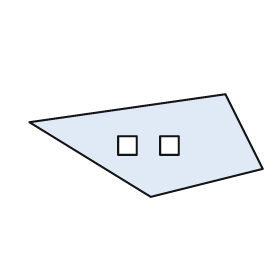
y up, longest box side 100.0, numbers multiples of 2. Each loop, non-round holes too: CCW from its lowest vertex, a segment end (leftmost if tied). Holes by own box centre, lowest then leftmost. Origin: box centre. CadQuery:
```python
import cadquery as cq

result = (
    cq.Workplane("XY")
    .moveTo(2.0, -22.0)
    .lineTo(50.0, -10.0)
    .lineTo(34.0, 22.0)
    .lineTo(-50.0, 10.0)
    .close()
    .moveTo(-12.0, -4.0)
    .lineTo(-4.0, -4.0)
    .lineTo(-4.0, 4.0)
    .lineTo(-12.0, 4.0)
    .close()
    .moveTo(6.0, -4.0)
    .lineTo(14.0, -4.0)
    .lineTo(14.0, 4.0)
    .lineTo(6.0, 4.0)
    .close()
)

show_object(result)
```